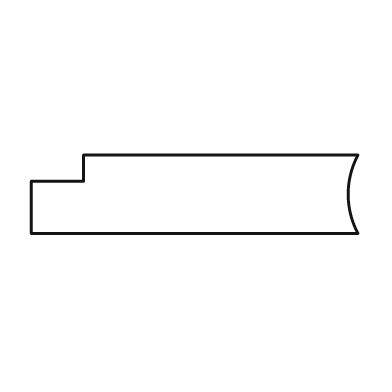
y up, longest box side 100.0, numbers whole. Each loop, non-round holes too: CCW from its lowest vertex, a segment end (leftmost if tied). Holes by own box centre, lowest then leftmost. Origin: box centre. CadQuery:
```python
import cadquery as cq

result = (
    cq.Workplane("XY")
    .moveTo(-50.0, -12.0)
    .lineTo(50.0, -12.0)
    .threePointArc((47.0, 0.0), (50.0, 12.0))
    .lineTo(-34.0, 12.0)
    .lineTo(-34.0, 4.0)
    .lineTo(-50.0, 4.0)
    .close()
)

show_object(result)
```